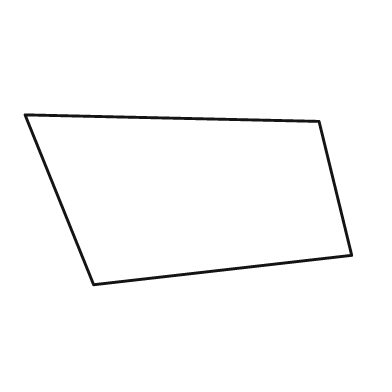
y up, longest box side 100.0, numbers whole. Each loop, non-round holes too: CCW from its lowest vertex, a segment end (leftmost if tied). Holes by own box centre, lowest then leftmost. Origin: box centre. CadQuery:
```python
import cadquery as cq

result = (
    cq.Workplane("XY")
    .moveTo(-29.0, -26.0)
    .lineTo(50.0, -17.0)
    .lineTo(40.0, 24.0)
    .lineTo(-50.0, 26.0)
    .close()
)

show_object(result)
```